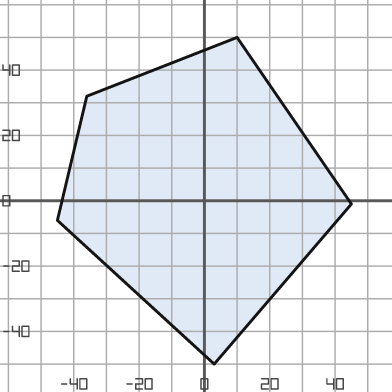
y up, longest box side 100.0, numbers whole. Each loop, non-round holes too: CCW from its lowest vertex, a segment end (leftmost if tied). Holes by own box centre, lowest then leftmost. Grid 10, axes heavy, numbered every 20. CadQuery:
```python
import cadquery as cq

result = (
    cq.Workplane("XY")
    .moveTo(3.0, -50.0)
    .lineTo(45.0, -1.0)
    .lineTo(10.0, 50.0)
    .lineTo(-36.0, 32.0)
    .lineTo(-45.0, -6.0)
    .close()
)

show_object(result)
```